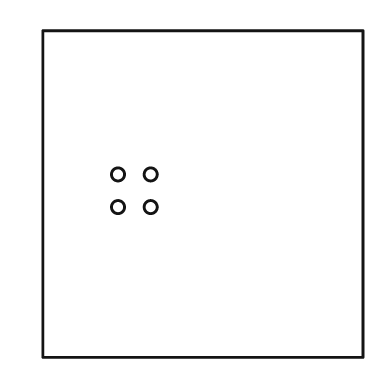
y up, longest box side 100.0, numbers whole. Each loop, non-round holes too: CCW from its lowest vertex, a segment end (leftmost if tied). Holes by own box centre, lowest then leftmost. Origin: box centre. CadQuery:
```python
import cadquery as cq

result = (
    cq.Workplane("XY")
    .moveTo(-49.0, -50.0)
    .lineTo(49.0, -50.0)
    .lineTo(49.0, 50.0)
    .lineTo(-49.0, 50.0)
    .close()
    .moveTo(-26.0, -4.0)
    .circle(2.0)
    .moveTo(-16.0, -4.0)
    .circle(2.0)
    .moveTo(-26.0, 6.0)
    .circle(2.0)
    .moveTo(-16.0, 6.0)
    .circle(2.0)
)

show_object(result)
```